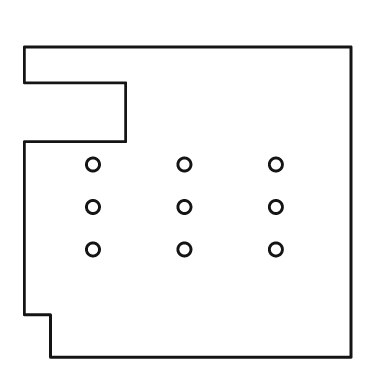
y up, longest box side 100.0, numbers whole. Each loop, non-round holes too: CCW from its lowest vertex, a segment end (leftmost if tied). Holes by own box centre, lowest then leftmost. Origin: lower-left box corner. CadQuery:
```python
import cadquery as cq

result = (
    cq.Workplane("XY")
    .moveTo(8.0, 0.0)
    .lineTo(100.0, 0.0)
    .lineTo(100.0, 95.0)
    .lineTo(0.0, 95.0)
    .lineTo(0.0, 84.0)
    .lineTo(31.0, 84.0)
    .lineTo(31.0, 66.0)
    .lineTo(0.0, 66.0)
    .lineTo(0.0, 13.0)
    .lineTo(8.0, 13.0)
    .close()
    .moveTo(21.0, 33.0)
    .circle(2.0)
    .moveTo(49.0, 33.0)
    .circle(2.0)
    .moveTo(77.0, 33.0)
    .circle(2.0)
    .moveTo(21.0, 46.0)
    .circle(2.0)
    .moveTo(49.0, 46.0)
    .circle(2.0)
    .moveTo(77.0, 46.0)
    .circle(2.0)
    .moveTo(21.0, 59.0)
    .circle(2.0)
    .moveTo(49.0, 59.0)
    .circle(2.0)
    .moveTo(77.0, 59.0)
    .circle(2.0)
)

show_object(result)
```